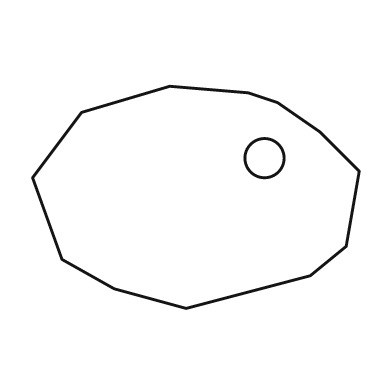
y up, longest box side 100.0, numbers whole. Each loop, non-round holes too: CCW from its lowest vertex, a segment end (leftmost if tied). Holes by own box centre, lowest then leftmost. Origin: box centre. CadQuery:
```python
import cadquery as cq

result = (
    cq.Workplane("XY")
    .moveTo(-3.0, -34.0)
    .lineTo(35.0, -24.0)
    .lineTo(46.0, -15.0)
    .lineTo(50.0, 8.0)
    .lineTo(38.0, 20.0)
    .lineTo(25.0, 29.0)
    .lineTo(16.0, 32.0)
    .lineTo(-8.0, 34.0)
    .lineTo(-35.0, 26.0)
    .lineTo(-50.0, 6.0)
    .lineTo(-41.0, -19.0)
    .lineTo(-25.0, -28.0)
    .close()
    .moveTo(21.0, 12.0)
    .circle(6.0)
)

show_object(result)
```